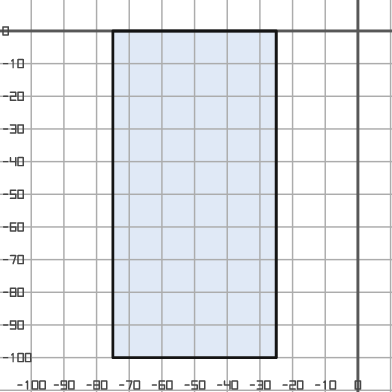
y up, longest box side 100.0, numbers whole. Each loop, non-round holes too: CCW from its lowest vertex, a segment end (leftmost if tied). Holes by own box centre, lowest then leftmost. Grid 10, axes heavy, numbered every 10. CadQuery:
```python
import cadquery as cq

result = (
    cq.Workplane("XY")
    .moveTo(-75.0, -100.0)
    .lineTo(-25.0, -100.0)
    .lineTo(-25.0, 0.0)
    .lineTo(-75.0, 0.0)
    .close()
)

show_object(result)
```